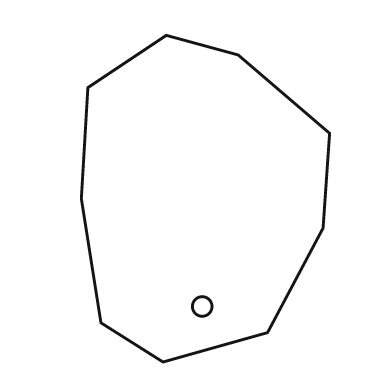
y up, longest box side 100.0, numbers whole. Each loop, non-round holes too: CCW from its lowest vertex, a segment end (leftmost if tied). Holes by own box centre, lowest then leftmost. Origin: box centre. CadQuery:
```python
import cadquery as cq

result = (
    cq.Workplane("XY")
    .moveTo(-13.0, -50.0)
    .lineTo(19.0, -41.0)
    .lineTo(36.0, -9.0)
    .lineTo(38.0, 20.0)
    .lineTo(10.0, 44.0)
    .lineTo(-12.0, 50.0)
    .lineTo(-36.0, 34.0)
    .lineTo(-38.0, 0.0)
    .lineTo(-32.0, -38.0)
    .close()
    .moveTo(-1.0, -33.0)
    .circle(3.0)
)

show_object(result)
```